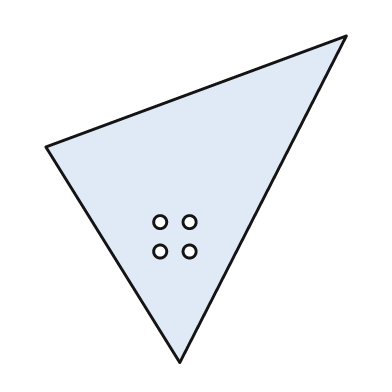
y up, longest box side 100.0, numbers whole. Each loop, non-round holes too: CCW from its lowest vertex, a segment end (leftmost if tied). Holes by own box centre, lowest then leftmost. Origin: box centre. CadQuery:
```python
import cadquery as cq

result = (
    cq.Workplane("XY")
    .moveTo(-5.0, -50.0)
    .lineTo(46.0, 50.0)
    .lineTo(-46.0, 16.0)
    .close()
    .moveTo(-11.0, -16.0)
    .circle(2.0)
    .moveTo(-2.0, -16.0)
    .circle(2.0)
    .moveTo(-11.0, -7.0)
    .circle(2.0)
    .moveTo(-2.0, -7.0)
    .circle(2.0)
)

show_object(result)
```